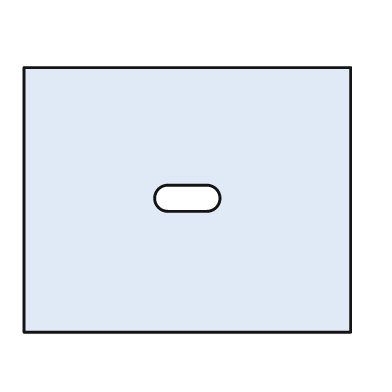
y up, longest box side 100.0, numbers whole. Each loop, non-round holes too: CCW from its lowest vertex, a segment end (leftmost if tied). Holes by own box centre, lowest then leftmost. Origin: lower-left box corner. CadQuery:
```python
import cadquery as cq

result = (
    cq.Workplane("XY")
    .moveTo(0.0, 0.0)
    .lineTo(100.0, 0.0)
    .lineTo(100.0, 81.0)
    .lineTo(0.0, 81.0)
    .close()
    .moveTo(44.0, 37.0)
    .lineTo(56.0, 37.0)
    .threePointArc((60.0, 41.0), (56.0, 45.0))
    .lineTo(44.0, 45.0)
    .threePointArc((40.0, 41.0), (44.0, 37.0))
    .close()
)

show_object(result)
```